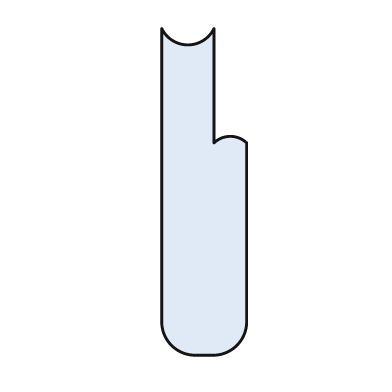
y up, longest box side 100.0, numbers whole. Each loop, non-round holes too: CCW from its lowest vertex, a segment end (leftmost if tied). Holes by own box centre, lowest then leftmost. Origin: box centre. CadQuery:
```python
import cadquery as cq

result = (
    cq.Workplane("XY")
    .moveTo(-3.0, -50.0)
    .lineTo(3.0, -50.0)
    .threePointArc((10.0, -47.0), (13.0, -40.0))
    .lineTo(13.0, 15.0)
    .threePointArc((8.0, 17.0), (3.0, 15.0))
    .lineTo(3.0, 50.0)
    .threePointArc((-5.0, 45.0), (-13.0, 50.0))
    .lineTo(-13.0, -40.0)
    .threePointArc((-10.0, -47.0), (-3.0, -50.0))
    .close()
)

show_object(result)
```